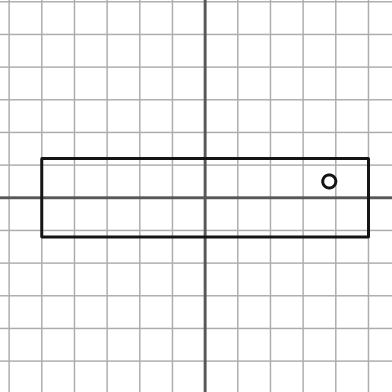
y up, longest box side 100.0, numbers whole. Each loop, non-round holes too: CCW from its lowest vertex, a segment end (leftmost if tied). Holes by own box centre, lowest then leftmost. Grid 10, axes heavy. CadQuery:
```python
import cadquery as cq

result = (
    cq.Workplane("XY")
    .moveTo(-50.0, -12.0)
    .lineTo(50.0, -12.0)
    .lineTo(50.0, 12.0)
    .lineTo(-50.0, 12.0)
    .close()
    .moveTo(38.0, 5.0)
    .circle(2.0)
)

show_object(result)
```